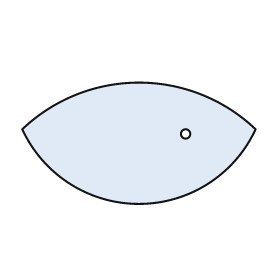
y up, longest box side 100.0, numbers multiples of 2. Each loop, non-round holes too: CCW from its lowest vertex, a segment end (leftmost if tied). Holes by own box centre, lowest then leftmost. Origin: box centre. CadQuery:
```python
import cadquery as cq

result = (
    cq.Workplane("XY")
    .moveTo(-50.0, 6.0)
    .threePointArc((0.0, -26.0), (50.0, 6.0))
    .threePointArc((0.0, 26.0), (-50.0, 6.0))
    .close()
    .moveTo(20.0, 4.0)
    .circle(2.0)
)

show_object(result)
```